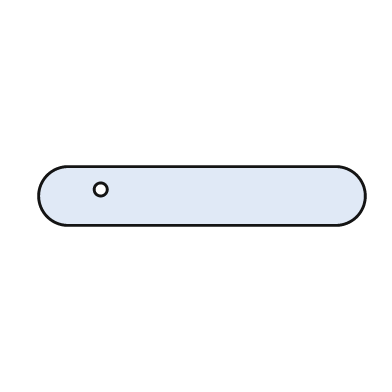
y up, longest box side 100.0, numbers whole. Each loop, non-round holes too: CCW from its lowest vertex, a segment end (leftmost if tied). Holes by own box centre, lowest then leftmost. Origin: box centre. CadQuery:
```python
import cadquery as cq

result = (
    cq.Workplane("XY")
    .moveTo(-41.0, -9.0)
    .lineTo(41.0, -9.0)
    .threePointArc((50.0, 0.0), (41.0, 9.0))
    .lineTo(-41.0, 9.0)
    .threePointArc((-50.0, 0.0), (-41.0, -9.0))
    .close()
    .moveTo(-31.0, 2.0)
    .circle(2.0)
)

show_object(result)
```